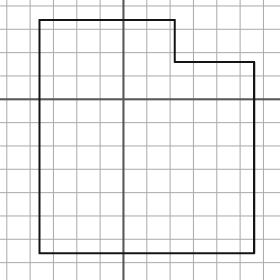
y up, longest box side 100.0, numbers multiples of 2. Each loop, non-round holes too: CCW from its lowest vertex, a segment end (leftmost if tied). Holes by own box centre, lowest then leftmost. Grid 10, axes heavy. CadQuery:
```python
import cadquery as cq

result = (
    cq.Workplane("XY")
    .moveTo(-36.0, -66.0)
    .lineTo(56.0, -66.0)
    .lineTo(56.0, 16.0)
    .lineTo(22.0, 16.0)
    .lineTo(22.0, 34.0)
    .lineTo(-36.0, 34.0)
    .close()
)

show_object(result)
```